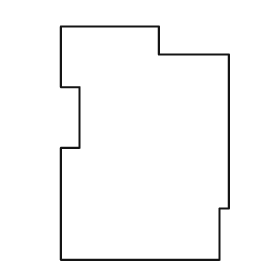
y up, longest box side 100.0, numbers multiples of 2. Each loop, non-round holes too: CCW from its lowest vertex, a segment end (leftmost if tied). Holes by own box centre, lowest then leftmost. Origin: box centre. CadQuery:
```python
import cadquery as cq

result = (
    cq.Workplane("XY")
    .moveTo(-36.0, -50.0)
    .lineTo(32.0, -50.0)
    .lineTo(32.0, -28.0)
    .lineTo(36.0, -28.0)
    .lineTo(36.0, 38.0)
    .lineTo(6.0, 38.0)
    .lineTo(6.0, 50.0)
    .lineTo(-36.0, 50.0)
    .lineTo(-36.0, 24.0)
    .lineTo(-28.0, 24.0)
    .lineTo(-28.0, -2.0)
    .lineTo(-36.0, -2.0)
    .close()
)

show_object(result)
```